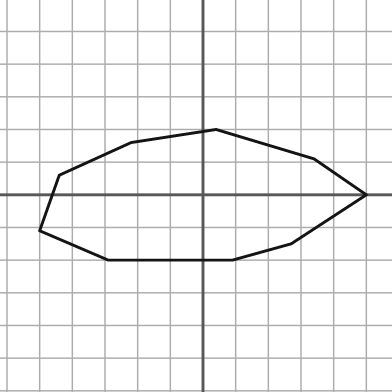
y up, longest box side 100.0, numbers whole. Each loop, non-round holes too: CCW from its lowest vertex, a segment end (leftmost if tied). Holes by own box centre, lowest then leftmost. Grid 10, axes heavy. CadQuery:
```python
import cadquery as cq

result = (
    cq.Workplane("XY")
    .moveTo(-29.0, -20.0)
    .lineTo(9.0, -20.0)
    .lineTo(27.0, -15.0)
    .lineTo(50.0, 0.0)
    .lineTo(34.0, 11.0)
    .lineTo(4.0, 20.0)
    .lineTo(-22.0, 16.0)
    .lineTo(-44.0, 6.0)
    .lineTo(-50.0, -11.0)
    .close()
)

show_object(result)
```